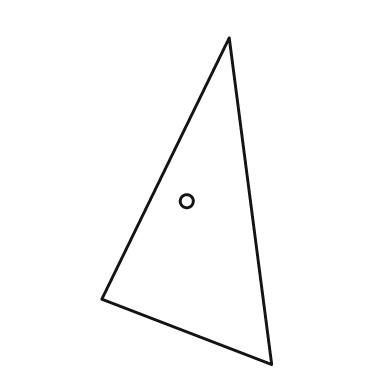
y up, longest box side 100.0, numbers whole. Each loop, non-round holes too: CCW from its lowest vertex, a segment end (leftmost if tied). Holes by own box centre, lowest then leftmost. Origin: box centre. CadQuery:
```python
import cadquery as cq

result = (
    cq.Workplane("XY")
    .moveTo(26.0, -50.0)
    .lineTo(13.0, 50.0)
    .lineTo(-26.0, -30.0)
    .close()
    .moveTo(0.0, 0.0)
    .circle(2.0)
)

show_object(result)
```